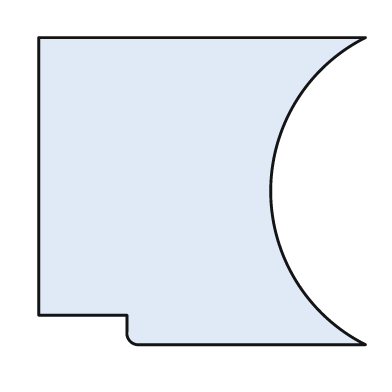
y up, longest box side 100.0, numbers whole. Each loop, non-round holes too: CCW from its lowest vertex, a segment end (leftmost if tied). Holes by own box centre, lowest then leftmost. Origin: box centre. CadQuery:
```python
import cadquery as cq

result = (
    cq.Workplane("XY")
    .moveTo(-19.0, -47.0)
    .lineTo(50.0, -47.0)
    .threePointArc((21.0, 0.0), (50.0, 47.0))
    .lineTo(-50.0, 47.0)
    .lineTo(-50.0, -38.0)
    .lineTo(-23.0, -38.0)
    .lineTo(-23.0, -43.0)
    .threePointArc((-22.0, -46.0), (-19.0, -47.0))
    .close()
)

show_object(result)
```